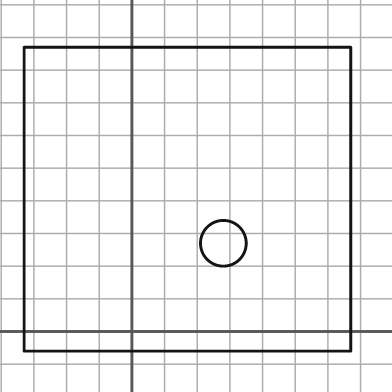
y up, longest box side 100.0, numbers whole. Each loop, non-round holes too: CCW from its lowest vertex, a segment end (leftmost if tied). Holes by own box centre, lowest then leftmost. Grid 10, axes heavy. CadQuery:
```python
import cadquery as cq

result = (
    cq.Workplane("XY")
    .moveTo(-33.0, -6.0)
    .lineTo(67.0, -6.0)
    .lineTo(67.0, 87.0)
    .lineTo(-33.0, 87.0)
    .close()
    .moveTo(28.0, 27.0)
    .circle(7.0)
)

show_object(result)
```